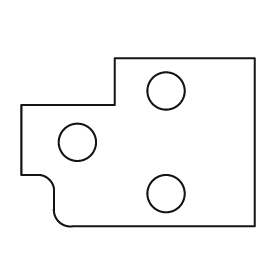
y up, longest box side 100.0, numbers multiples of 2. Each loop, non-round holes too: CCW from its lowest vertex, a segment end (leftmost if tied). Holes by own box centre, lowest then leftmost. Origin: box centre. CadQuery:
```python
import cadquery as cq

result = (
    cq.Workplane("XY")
    .moveTo(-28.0, -36.0)
    .lineTo(50.0, -36.0)
    .lineTo(50.0, 36.0)
    .lineTo(-10.0, 36.0)
    .lineTo(-10.0, 16.0)
    .lineTo(-50.0, 16.0)
    .lineTo(-50.0, -14.0)
    .lineTo(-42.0, -14.0)
    .threePointArc((-38.0, -16.0), (-36.0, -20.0))
    .lineTo(-36.0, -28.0)
    .threePointArc((-34.0, -34.0), (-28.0, -36.0))
    .close()
    .moveTo(12.0, -22.0)
    .circle(8.0)
    .moveTo(-26.0, 0.0)
    .circle(8.0)
    .moveTo(12.0, 22.0)
    .circle(8.0)
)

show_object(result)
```